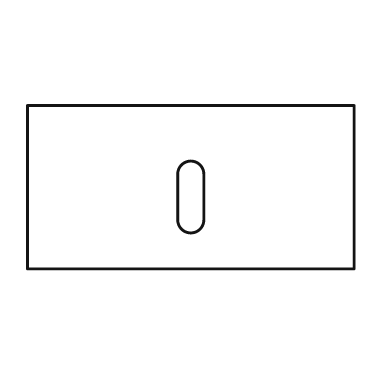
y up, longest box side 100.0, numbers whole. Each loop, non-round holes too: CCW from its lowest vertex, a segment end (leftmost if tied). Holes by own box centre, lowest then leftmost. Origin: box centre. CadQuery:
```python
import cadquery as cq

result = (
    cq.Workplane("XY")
    .moveTo(-50.0, -25.0)
    .lineTo(50.0, -25.0)
    .lineTo(50.0, 25.0)
    .lineTo(-50.0, 25.0)
    .close()
    .moveTo(-4.0, -10.0)
    .threePointArc((0.0, -14.0), (4.0, -10.0))
    .lineTo(4.0, 4.0)
    .threePointArc((0.0, 8.0), (-4.0, 4.0))
    .close()
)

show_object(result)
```